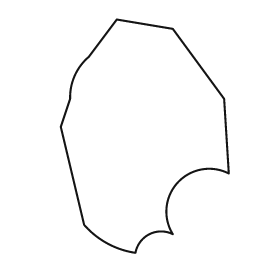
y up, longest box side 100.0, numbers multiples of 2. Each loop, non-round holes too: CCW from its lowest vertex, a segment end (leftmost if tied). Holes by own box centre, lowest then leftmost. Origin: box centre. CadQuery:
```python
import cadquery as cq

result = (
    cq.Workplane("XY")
    .moveTo(-4.0, -50.0)
    .threePointArc((2.0, -42.0), (12.0, -42.0))
    .threePointArc((14.0, -20.0), (36.0, -16.0))
    .lineTo(34.0, 16.0)
    .lineTo(12.0, 46.0)
    .lineTo(-12.0, 50.0)
    .lineTo(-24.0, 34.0)
    .threePointArc((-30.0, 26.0), (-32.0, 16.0))
    .lineTo(-36.0, 4.0)
    .lineTo(-26.0, -38.0)
    .threePointArc((-16.0, -46.0), (-4.0, -50.0))
    .close()
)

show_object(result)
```